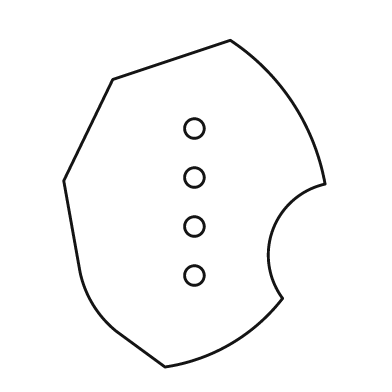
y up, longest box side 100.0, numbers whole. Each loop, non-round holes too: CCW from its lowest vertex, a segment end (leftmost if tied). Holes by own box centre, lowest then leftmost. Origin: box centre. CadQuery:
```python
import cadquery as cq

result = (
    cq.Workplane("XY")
    .moveTo(-9.0, -50.0)
    .threePointArc((11.0, -43.0), (27.0, -29.0))
    .threePointArc((24.0, -8.0), (40.0, 6.0))
    .threePointArc((30.0, 31.0), (11.0, 50.0))
    .lineTo(-25.0, 38.0)
    .lineTo(-40.0, 7.0)
    .lineTo(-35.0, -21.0)
    .threePointArc((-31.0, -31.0), (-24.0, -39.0))
    .close()
    .moveTo(0.0, -22.0)
    .circle(3.0)
    .moveTo(0.0, -7.0)
    .circle(3.0)
    .moveTo(0.0, 8.0)
    .circle(3.0)
    .moveTo(0.0, 23.0)
    .circle(3.0)
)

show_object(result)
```